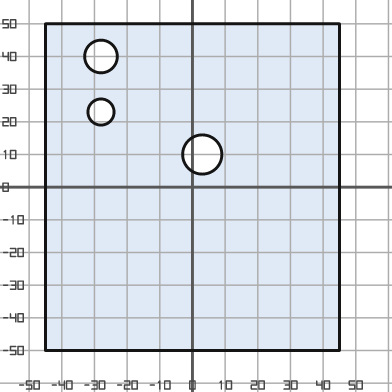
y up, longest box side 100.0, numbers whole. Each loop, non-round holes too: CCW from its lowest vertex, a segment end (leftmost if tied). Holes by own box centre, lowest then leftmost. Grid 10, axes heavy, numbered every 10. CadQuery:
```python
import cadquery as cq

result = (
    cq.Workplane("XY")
    .moveTo(-45.0, -50.0)
    .lineTo(45.0, -50.0)
    .lineTo(45.0, 50.0)
    .lineTo(-45.0, 50.0)
    .close()
    .moveTo(3.0, 10.0)
    .circle(6.0)
    .moveTo(-28.0, 23.0)
    .circle(4.0)
    .moveTo(-28.0, 40.0)
    .circle(5.0)
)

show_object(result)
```